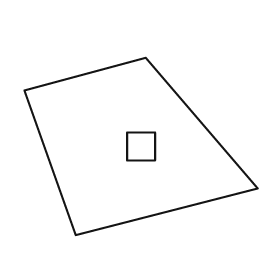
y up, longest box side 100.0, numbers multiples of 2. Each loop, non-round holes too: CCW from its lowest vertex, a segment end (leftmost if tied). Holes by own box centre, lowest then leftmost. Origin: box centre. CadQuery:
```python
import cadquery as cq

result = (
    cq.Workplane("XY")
    .moveTo(-28.0, -38.0)
    .lineTo(50.0, -18.0)
    .lineTo(2.0, 38.0)
    .lineTo(-50.0, 24.0)
    .close()
    .moveTo(-6.0, -6.0)
    .lineTo(6.0, -6.0)
    .lineTo(6.0, 6.0)
    .lineTo(-6.0, 6.0)
    .close()
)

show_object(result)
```